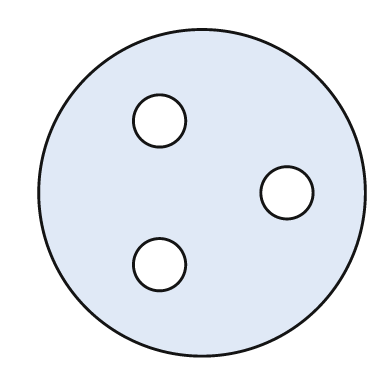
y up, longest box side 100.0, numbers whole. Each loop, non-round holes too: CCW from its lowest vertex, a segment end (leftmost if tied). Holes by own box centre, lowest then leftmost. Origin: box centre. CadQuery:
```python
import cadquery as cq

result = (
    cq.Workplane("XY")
    .moveTo(0.0, 0.0)
    .circle(50.0)
    .moveTo(-13.0, -22.0)
    .circle(8.0)
    .moveTo(26.0, 0.0)
    .circle(8.0)
    .moveTo(-13.0, 22.0)
    .circle(8.0)
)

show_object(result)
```